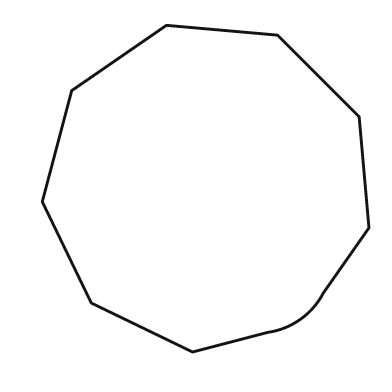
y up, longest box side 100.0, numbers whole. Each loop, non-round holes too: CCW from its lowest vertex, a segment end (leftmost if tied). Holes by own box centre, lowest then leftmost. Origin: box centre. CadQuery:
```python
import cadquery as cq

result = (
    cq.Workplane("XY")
    .moveTo(-4.0, -50.0)
    .lineTo(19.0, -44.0)
    .threePointArc((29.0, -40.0), (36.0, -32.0))
    .lineTo(50.0, -12.0)
    .lineTo(47.0, 22.0)
    .lineTo(22.0, 47.0)
    .lineTo(-12.0, 50.0)
    .lineTo(-41.0, 30.0)
    .lineTo(-50.0, -4.0)
    .lineTo(-35.0, -35.0)
    .close()
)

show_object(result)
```